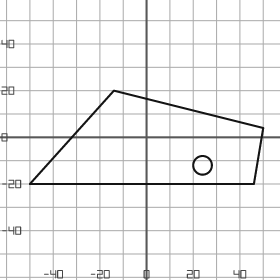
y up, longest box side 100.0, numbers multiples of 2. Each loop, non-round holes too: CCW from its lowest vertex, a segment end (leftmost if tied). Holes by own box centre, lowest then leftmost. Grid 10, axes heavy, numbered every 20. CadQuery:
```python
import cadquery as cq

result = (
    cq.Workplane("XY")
    .moveTo(-50.0, -20.0)
    .lineTo(46.0, -20.0)
    .lineTo(50.0, 4.0)
    .lineTo(-14.0, 20.0)
    .close()
    .moveTo(24.0, -12.0)
    .circle(4.0)
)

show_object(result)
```